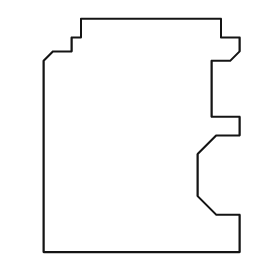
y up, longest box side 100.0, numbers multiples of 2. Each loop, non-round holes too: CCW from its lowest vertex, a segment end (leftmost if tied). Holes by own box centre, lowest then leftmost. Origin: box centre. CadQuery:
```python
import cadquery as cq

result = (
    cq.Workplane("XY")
    .moveTo(-42.0, -50.0)
    .lineTo(42.0, -50.0)
    .lineTo(42.0, -34.0)
    .lineTo(32.0, -34.0)
    .lineTo(24.0, -26.0)
    .lineTo(24.0, -8.0)
    .lineTo(32.0, 0.0)
    .lineTo(42.0, 0.0)
    .lineTo(42.0, 8.0)
    .lineTo(30.0, 8.0)
    .lineTo(30.0, 32.0)
    .lineTo(38.0, 32.0)
    .lineTo(42.0, 36.0)
    .lineTo(42.0, 42.0)
    .lineTo(34.0, 42.0)
    .lineTo(34.0, 50.0)
    .lineTo(-26.0, 50.0)
    .lineTo(-26.0, 42.0)
    .lineTo(-30.0, 42.0)
    .lineTo(-30.0, 36.0)
    .lineTo(-38.0, 36.0)
    .lineTo(-42.0, 32.0)
    .close()
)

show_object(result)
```